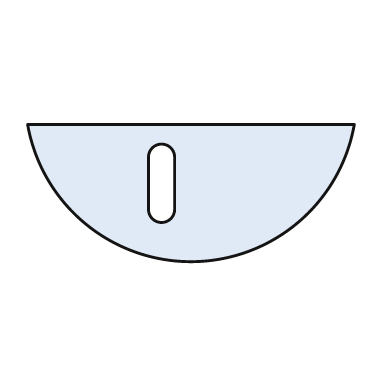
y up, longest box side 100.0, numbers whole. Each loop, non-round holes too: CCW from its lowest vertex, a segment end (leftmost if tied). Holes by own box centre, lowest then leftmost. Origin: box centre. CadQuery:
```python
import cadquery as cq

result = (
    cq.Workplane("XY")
    .moveTo(-50.0, 21.0)
    .threePointArc((0.0, -21.0), (50.0, 21.0))
    .close()
    .moveTo(-13.0, -5.0)
    .threePointArc((-9.0, -9.0), (-5.0, -5.0))
    .lineTo(-5.0, 11.0)
    .threePointArc((-9.0, 15.0), (-13.0, 11.0))
    .close()
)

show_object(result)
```